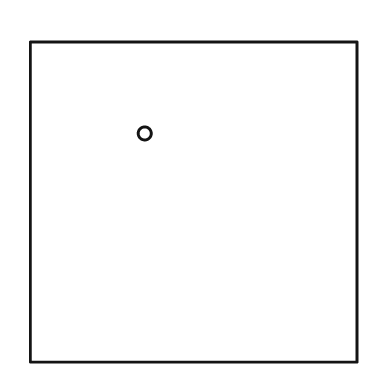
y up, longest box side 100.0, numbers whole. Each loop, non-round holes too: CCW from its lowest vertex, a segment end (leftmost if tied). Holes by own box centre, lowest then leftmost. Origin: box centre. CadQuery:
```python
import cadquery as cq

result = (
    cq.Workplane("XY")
    .moveTo(-50.0, -49.0)
    .lineTo(50.0, -49.0)
    .lineTo(50.0, 49.0)
    .lineTo(-50.0, 49.0)
    .close()
    .moveTo(-15.0, 21.0)
    .circle(2.0)
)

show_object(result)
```